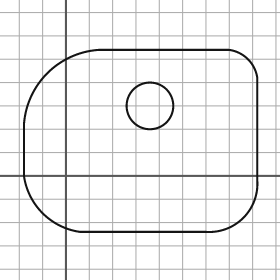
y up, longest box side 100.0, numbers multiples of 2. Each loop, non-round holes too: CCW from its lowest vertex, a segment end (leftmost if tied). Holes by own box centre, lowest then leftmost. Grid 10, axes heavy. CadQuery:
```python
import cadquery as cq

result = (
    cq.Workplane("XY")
    .moveTo(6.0, -24.0)
    .lineTo(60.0, -24.0)
    .threePointArc((76.0, -18.0), (82.0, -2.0))
    .lineTo(82.0, 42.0)
    .threePointArc((78.0, 50.0), (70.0, 54.0))
    .lineTo(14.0, 54.0)
    .threePointArc((-8.0, 44.0), (-18.0, 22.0))
    .lineTo(-18.0, 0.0)
    .threePointArc((-10.0, -16.0), (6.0, -24.0))
    .close()
    .moveTo(36.0, 30.0)
    .circle(10.0)
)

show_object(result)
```